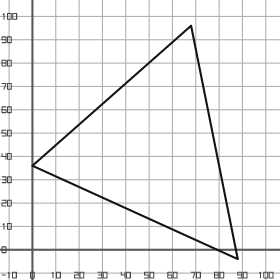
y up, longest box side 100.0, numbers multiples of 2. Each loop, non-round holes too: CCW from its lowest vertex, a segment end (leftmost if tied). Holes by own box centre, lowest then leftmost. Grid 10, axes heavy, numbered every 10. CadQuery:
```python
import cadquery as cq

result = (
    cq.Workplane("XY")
    .moveTo(88.0, -4.0)
    .lineTo(68.0, 96.0)
    .lineTo(0.0, 36.0)
    .close()
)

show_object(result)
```